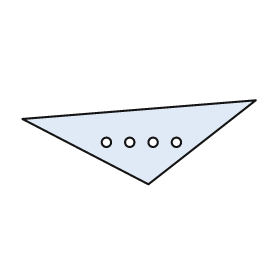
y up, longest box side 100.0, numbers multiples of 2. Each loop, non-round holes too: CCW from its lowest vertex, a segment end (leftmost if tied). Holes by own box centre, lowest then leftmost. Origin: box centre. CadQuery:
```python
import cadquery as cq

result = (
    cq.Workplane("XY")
    .moveTo(4.0, -18.0)
    .lineTo(50.0, 18.0)
    .lineTo(-50.0, 10.0)
    .close()
    .moveTo(-14.0, 0.0)
    .circle(2.0)
    .moveTo(-4.0, 0.0)
    .circle(2.0)
    .moveTo(6.0, 0.0)
    .circle(2.0)
    .moveTo(16.0, 0.0)
    .circle(2.0)
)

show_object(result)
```